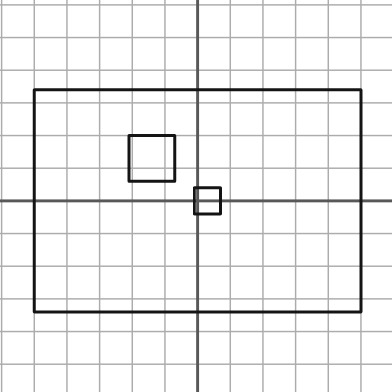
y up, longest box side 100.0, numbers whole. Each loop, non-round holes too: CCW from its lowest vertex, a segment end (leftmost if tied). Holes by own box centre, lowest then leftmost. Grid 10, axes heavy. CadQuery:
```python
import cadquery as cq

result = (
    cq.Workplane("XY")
    .moveTo(-50.0, -34.0)
    .lineTo(50.0, -34.0)
    .lineTo(50.0, 34.0)
    .lineTo(-50.0, 34.0)
    .close()
    .moveTo(-1.0, -4.0)
    .lineTo(7.0, -4.0)
    .lineTo(7.0, 4.0)
    .lineTo(-1.0, 4.0)
    .close()
    .moveTo(-21.0, 6.0)
    .lineTo(-7.0, 6.0)
    .lineTo(-7.0, 20.0)
    .lineTo(-21.0, 20.0)
    .close()
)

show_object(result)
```